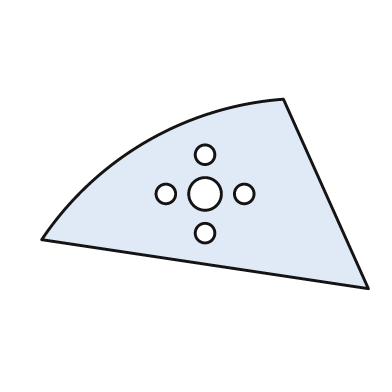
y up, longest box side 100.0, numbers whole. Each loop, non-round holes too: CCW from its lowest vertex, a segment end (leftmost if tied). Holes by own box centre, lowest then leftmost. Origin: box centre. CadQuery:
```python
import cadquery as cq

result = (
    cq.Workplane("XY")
    .moveTo(50.0, -29.0)
    .lineTo(24.0, 29.0)
    .threePointArc((-18.0, 16.0), (-50.0, -14.0))
    .close()
    .moveTo(0.0, -12.0)
    .circle(3.0)
    .moveTo(-12.0, 0.0)
    .circle(3.0)
    .moveTo(0.0, 0.0)
    .circle(5.0)
    .moveTo(12.0, 0.0)
    .circle(3.0)
    .moveTo(0.0, 12.0)
    .circle(3.0)
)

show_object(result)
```